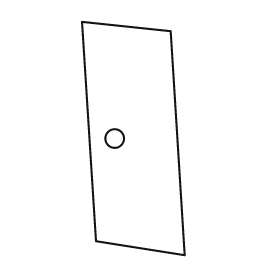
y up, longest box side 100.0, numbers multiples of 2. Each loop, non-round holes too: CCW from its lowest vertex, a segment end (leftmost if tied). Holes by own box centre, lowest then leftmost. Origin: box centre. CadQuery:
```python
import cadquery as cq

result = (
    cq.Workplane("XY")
    .moveTo(22.0, -50.0)
    .lineTo(16.0, 46.0)
    .lineTo(-22.0, 50.0)
    .lineTo(-16.0, -44.0)
    .close()
    .moveTo(-8.0, 0.0)
    .circle(4.0)
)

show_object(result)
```